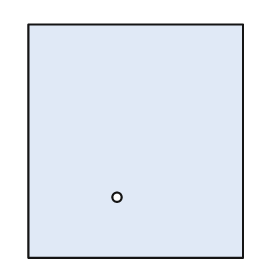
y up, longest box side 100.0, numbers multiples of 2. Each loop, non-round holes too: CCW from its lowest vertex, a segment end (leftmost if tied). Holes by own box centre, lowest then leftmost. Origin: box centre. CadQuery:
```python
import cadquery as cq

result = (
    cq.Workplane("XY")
    .moveTo(-46.0, -50.0)
    .lineTo(46.0, -50.0)
    .lineTo(46.0, 50.0)
    .lineTo(-46.0, 50.0)
    .close()
    .moveTo(-8.0, -24.0)
    .circle(2.0)
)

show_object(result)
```